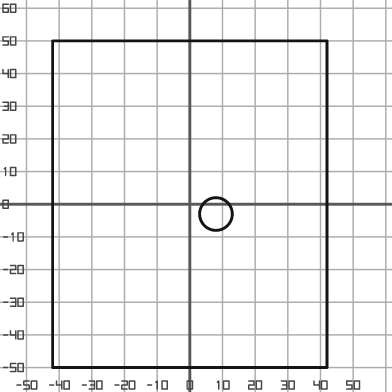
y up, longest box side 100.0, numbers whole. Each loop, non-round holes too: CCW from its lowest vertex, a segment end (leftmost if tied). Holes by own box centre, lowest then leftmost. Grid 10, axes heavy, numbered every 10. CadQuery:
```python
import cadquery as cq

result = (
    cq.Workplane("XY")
    .moveTo(-42.0, -50.0)
    .lineTo(42.0, -50.0)
    .lineTo(42.0, 50.0)
    .lineTo(-42.0, 50.0)
    .close()
    .moveTo(8.0, -3.0)
    .circle(5.0)
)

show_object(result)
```